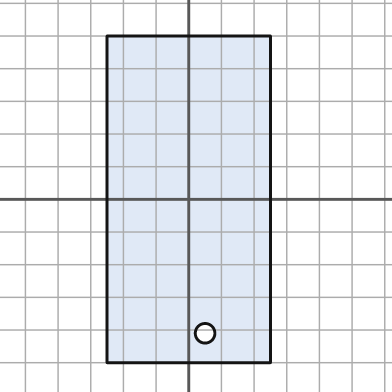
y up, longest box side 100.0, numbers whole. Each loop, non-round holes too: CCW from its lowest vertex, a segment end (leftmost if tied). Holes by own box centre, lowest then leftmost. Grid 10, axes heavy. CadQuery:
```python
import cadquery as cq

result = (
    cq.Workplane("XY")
    .moveTo(-25.0, -50.0)
    .lineTo(25.0, -50.0)
    .lineTo(25.0, 50.0)
    .lineTo(-25.0, 50.0)
    .close()
    .moveTo(5.0, -41.0)
    .circle(3.0)
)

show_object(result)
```